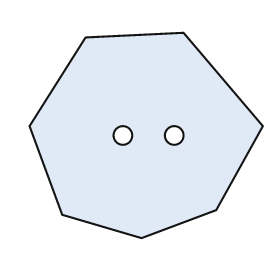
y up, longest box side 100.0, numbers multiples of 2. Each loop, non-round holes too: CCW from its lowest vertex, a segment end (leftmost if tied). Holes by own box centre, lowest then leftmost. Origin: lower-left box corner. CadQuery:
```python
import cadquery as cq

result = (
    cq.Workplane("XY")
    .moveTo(48.0, 0.0)
    .lineTo(80.0, 12.0)
    .lineTo(100.0, 48.0)
    .lineTo(66.0, 88.0)
    .lineTo(24.0, 86.0)
    .lineTo(0.0, 48.0)
    .lineTo(14.0, 10.0)
    .close()
    .moveTo(40.0, 44.0)
    .circle(4.0)
    .moveTo(62.0, 44.0)
    .circle(4.0)
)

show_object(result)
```